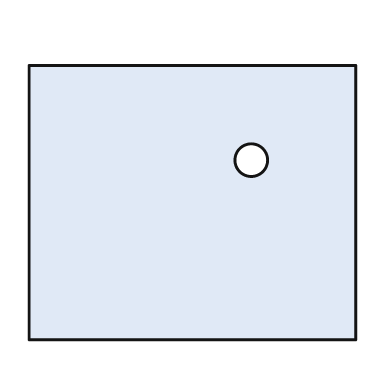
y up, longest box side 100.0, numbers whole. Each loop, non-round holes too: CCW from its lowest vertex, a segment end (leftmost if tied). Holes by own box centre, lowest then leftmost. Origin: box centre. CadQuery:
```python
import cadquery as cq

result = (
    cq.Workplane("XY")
    .moveTo(-50.0, -42.0)
    .lineTo(50.0, -42.0)
    .lineTo(50.0, 42.0)
    .lineTo(-50.0, 42.0)
    .close()
    .moveTo(18.0, 13.0)
    .circle(5.0)
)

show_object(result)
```